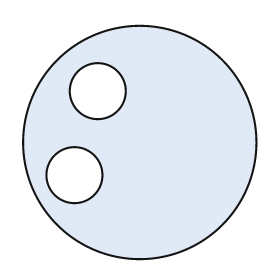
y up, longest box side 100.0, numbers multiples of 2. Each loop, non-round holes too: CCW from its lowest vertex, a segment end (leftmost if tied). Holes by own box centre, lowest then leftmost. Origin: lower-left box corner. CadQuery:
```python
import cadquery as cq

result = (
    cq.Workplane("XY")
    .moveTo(50.0, 50.0)
    .circle(50.0)
    .moveTo(22.0, 36.0)
    .circle(12.0)
    .moveTo(32.0, 72.0)
    .circle(12.0)
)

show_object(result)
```